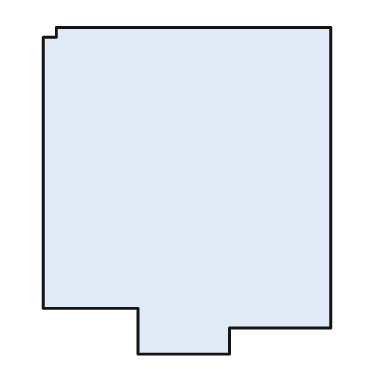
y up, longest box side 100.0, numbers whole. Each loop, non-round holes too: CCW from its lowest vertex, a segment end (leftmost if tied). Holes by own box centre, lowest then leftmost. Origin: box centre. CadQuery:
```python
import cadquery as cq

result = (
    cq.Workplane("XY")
    .moveTo(-15.0, -50.0)
    .lineTo(13.0, -50.0)
    .lineTo(13.0, -42.0)
    .lineTo(44.0, -42.0)
    .lineTo(44.0, 50.0)
    .lineTo(-40.0, 50.0)
    .lineTo(-40.0, 47.0)
    .lineTo(-44.0, 47.0)
    .lineTo(-44.0, -36.0)
    .lineTo(-15.0, -36.0)
    .close()
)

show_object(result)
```